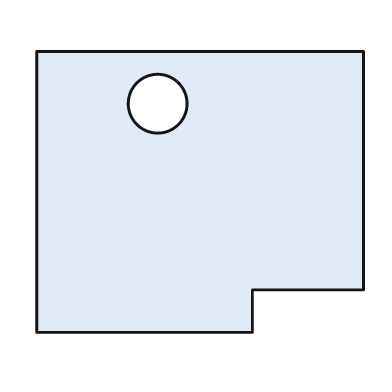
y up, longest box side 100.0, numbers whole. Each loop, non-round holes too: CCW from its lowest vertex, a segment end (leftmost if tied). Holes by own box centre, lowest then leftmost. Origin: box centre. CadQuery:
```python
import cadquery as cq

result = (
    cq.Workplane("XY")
    .moveTo(-50.0, -43.0)
    .lineTo(16.0, -43.0)
    .lineTo(16.0, -30.0)
    .lineTo(50.0, -30.0)
    .lineTo(50.0, 43.0)
    .lineTo(-50.0, 43.0)
    .close()
    .moveTo(-13.0, 27.0)
    .circle(9.0)
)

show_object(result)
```